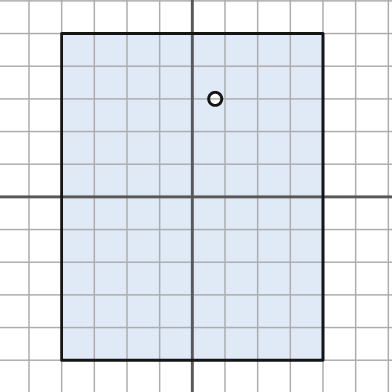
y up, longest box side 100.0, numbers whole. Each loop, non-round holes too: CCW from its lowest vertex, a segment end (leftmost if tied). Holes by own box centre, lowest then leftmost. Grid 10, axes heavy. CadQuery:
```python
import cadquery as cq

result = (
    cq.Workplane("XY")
    .moveTo(-40.0, -50.0)
    .lineTo(40.0, -50.0)
    .lineTo(40.0, 50.0)
    .lineTo(-40.0, 50.0)
    .close()
    .moveTo(7.0, 30.0)
    .circle(2.0)
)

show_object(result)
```